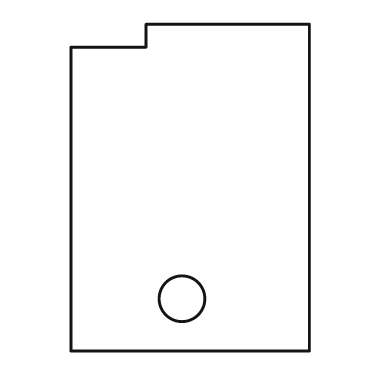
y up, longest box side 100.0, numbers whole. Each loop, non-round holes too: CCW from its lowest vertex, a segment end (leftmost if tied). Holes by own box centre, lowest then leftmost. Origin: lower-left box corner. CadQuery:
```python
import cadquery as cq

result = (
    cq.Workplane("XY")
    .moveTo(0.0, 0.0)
    .lineTo(73.0, 0.0)
    .lineTo(73.0, 100.0)
    .lineTo(23.0, 100.0)
    .lineTo(23.0, 93.0)
    .lineTo(0.0, 93.0)
    .close()
    .moveTo(34.0, 16.0)
    .circle(7.0)
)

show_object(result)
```